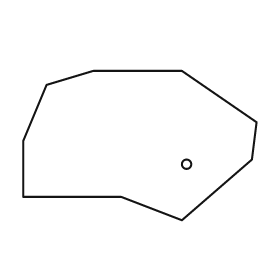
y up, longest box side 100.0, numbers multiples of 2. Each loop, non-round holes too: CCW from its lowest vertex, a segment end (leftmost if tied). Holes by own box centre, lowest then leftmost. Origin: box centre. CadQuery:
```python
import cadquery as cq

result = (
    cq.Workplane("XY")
    .moveTo(18.0, -32.0)
    .lineTo(48.0, -6.0)
    .lineTo(50.0, 10.0)
    .lineTo(18.0, 32.0)
    .lineTo(-20.0, 32.0)
    .lineTo(-40.0, 26.0)
    .lineTo(-50.0, 2.0)
    .lineTo(-50.0, -22.0)
    .lineTo(-8.0, -22.0)
    .close()
    .moveTo(20.0, -8.0)
    .circle(2.0)
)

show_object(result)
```